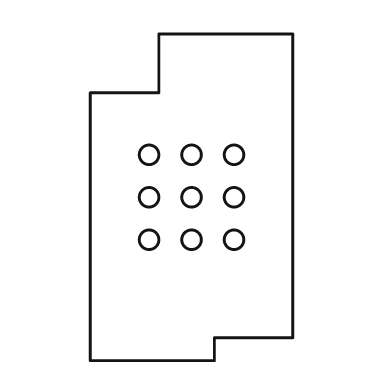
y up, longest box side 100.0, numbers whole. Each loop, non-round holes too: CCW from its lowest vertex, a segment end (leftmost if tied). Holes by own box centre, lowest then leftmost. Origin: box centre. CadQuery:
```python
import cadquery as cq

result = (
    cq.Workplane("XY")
    .moveTo(-31.0, -50.0)
    .lineTo(7.0, -50.0)
    .lineTo(7.0, -43.0)
    .lineTo(31.0, -43.0)
    .lineTo(31.0, 50.0)
    .lineTo(-10.0, 50.0)
    .lineTo(-10.0, 32.0)
    .lineTo(-31.0, 32.0)
    .close()
    .moveTo(-13.0, -13.0)
    .circle(3.0)
    .moveTo(0.0, -13.0)
    .circle(3.0)
    .moveTo(13.0, -13.0)
    .circle(3.0)
    .moveTo(-13.0, 0.0)
    .circle(3.0)
    .moveTo(0.0, 0.0)
    .circle(3.0)
    .moveTo(13.0, 0.0)
    .circle(3.0)
    .moveTo(-13.0, 13.0)
    .circle(3.0)
    .moveTo(0.0, 13.0)
    .circle(3.0)
    .moveTo(13.0, 13.0)
    .circle(3.0)
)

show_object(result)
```